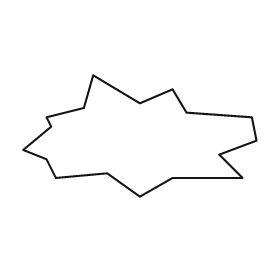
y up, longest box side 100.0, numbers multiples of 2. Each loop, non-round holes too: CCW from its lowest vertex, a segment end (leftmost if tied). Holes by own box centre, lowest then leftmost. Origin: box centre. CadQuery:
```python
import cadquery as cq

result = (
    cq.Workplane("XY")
    .moveTo(0.0, -26.0)
    .lineTo(14.0, -18.0)
    .lineTo(44.0, -18.0)
    .lineTo(34.0, -8.0)
    .lineTo(50.0, -2.0)
    .lineTo(48.0, 8.0)
    .lineTo(20.0, 10.0)
    .lineTo(14.0, 20.0)
    .lineTo(0.0, 14.0)
    .lineTo(-20.0, 26.0)
    .lineTo(-24.0, 12.0)
    .lineTo(-40.0, 8.0)
    .lineTo(-38.0, 4.0)
    .lineTo(-50.0, -6.0)
    .lineTo(-40.0, -10.0)
    .lineTo(-36.0, -18.0)
    .lineTo(-14.0, -16.0)
    .close()
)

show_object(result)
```